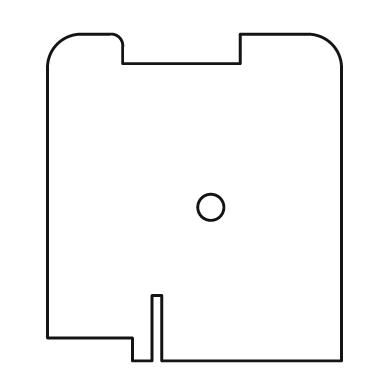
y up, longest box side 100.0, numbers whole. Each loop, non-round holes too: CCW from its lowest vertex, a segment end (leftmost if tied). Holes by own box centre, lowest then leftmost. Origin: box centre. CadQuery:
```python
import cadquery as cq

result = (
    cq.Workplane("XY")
    .moveTo(-19.0, -50.0)
    .lineTo(-13.0, -50.0)
    .lineTo(-13.0, -30.0)
    .lineTo(-10.0, -30.0)
    .lineTo(-10.0, -50.0)
    .lineTo(45.0, -50.0)
    .lineTo(45.0, 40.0)
    .threePointArc((42.0, 47.0), (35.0, 50.0))
    .lineTo(14.0, 50.0)
    .lineTo(14.0, 41.0)
    .lineTo(-22.0, 41.0)
    .lineTo(-22.0, 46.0)
    .threePointArc((-23.0, 49.0), (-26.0, 50.0))
    .lineTo(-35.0, 50.0)
    .threePointArc((-42.0, 47.0), (-45.0, 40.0))
    .lineTo(-45.0, -43.0)
    .lineTo(-19.0, -43.0)
    .close()
    .moveTo(5.0, -3.0)
    .circle(4.0)
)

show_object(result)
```